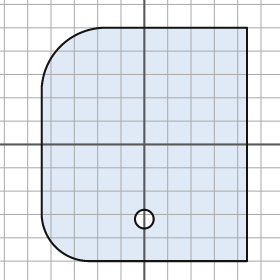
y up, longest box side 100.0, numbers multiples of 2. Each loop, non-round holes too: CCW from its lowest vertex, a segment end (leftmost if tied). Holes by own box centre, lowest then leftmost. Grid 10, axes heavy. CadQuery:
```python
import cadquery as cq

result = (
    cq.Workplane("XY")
    .moveTo(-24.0, -50.0)
    .lineTo(44.0, -50.0)
    .lineTo(44.0, 50.0)
    .lineTo(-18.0, 50.0)
    .threePointArc((-36.0, 42.0), (-44.0, 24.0))
    .lineTo(-44.0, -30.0)
    .threePointArc((-38.0, -44.0), (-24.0, -50.0))
    .close()
    .moveTo(0.0, -32.0)
    .circle(4.0)
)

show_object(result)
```